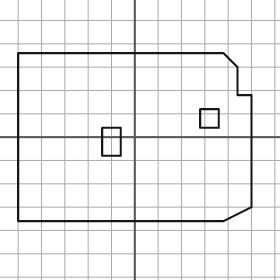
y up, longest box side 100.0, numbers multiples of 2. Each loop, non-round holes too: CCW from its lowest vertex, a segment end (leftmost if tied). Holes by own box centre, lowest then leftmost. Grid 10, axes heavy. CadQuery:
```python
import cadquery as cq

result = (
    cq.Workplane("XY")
    .moveTo(-50.0, -36.0)
    .lineTo(38.0, -36.0)
    .lineTo(50.0, -30.0)
    .lineTo(50.0, 18.0)
    .lineTo(44.0, 18.0)
    .lineTo(44.0, 30.0)
    .lineTo(38.0, 36.0)
    .lineTo(-50.0, 36.0)
    .close()
    .moveTo(-14.0, -8.0)
    .lineTo(-6.0, -8.0)
    .lineTo(-6.0, 4.0)
    .lineTo(-14.0, 4.0)
    .close()
    .moveTo(28.0, 4.0)
    .lineTo(36.0, 4.0)
    .lineTo(36.0, 12.0)
    .lineTo(28.0, 12.0)
    .close()
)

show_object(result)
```